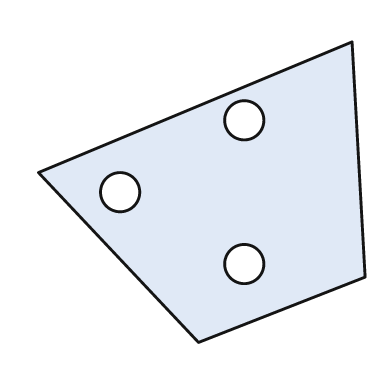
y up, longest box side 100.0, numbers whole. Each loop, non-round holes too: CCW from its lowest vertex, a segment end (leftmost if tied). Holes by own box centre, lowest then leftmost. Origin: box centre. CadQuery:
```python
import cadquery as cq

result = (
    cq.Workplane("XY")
    .moveTo(-1.0, -46.0)
    .lineTo(50.0, -26.0)
    .lineTo(46.0, 46.0)
    .lineTo(-50.0, 6.0)
    .close()
    .moveTo(13.0, -22.0)
    .circle(6.0)
    .moveTo(-25.0, 0.0)
    .circle(6.0)
    .moveTo(13.0, 22.0)
    .circle(6.0)
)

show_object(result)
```